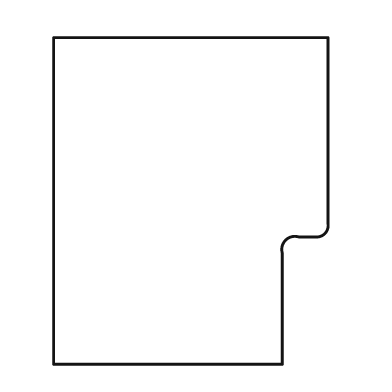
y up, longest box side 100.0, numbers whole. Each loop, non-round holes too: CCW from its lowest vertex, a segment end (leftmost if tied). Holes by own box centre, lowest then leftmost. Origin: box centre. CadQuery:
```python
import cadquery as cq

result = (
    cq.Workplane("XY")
    .moveTo(-42.0, -50.0)
    .lineTo(28.0, -50.0)
    .lineTo(28.0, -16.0)
    .threePointArc((29.0, -12.0), (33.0, -11.0))
    .lineTo(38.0, -11.0)
    .threePointArc((41.0, -10.0), (42.0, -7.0))
    .lineTo(42.0, 50.0)
    .lineTo(-42.0, 50.0)
    .close()
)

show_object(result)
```